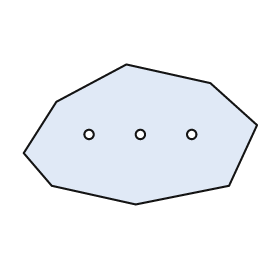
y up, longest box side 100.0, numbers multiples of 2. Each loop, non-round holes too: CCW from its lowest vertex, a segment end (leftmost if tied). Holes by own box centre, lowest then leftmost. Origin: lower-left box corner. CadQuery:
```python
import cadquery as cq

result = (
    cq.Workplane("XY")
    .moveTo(48.0, 0.0)
    .lineTo(88.0, 8.0)
    .lineTo(100.0, 34.0)
    .lineTo(80.0, 52.0)
    .lineTo(44.0, 60.0)
    .lineTo(14.0, 44.0)
    .lineTo(0.0, 22.0)
    .lineTo(12.0, 8.0)
    .close()
    .moveTo(28.0, 30.0)
    .circle(2.0)
    .moveTo(50.0, 30.0)
    .circle(2.0)
    .moveTo(72.0, 30.0)
    .circle(2.0)
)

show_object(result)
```